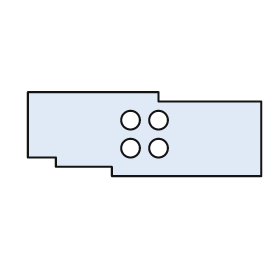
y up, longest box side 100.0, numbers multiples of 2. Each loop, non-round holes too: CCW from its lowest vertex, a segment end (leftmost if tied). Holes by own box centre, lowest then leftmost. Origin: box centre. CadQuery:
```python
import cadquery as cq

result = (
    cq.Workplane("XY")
    .moveTo(-14.0, -18.0)
    .lineTo(50.0, -18.0)
    .lineTo(50.0, 14.0)
    .lineTo(6.0, 14.0)
    .lineTo(6.0, 18.0)
    .lineTo(-50.0, 18.0)
    .lineTo(-50.0, -10.0)
    .lineTo(-38.0, -10.0)
    .lineTo(-38.0, -14.0)
    .lineTo(-14.0, -14.0)
    .close()
    .moveTo(-6.0, -6.0)
    .circle(4.0)
    .moveTo(6.0, -6.0)
    .circle(4.0)
    .moveTo(-6.0, 6.0)
    .circle(4.0)
    .moveTo(6.0, 6.0)
    .circle(4.0)
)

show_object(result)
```